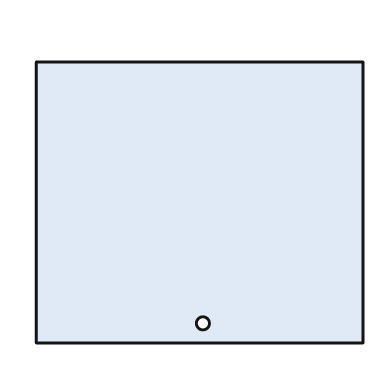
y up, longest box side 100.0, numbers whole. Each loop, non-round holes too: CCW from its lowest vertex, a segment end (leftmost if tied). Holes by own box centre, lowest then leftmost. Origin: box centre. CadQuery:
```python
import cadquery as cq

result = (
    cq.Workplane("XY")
    .moveTo(-50.0, -43.0)
    .lineTo(50.0, -43.0)
    .lineTo(50.0, 43.0)
    .lineTo(-50.0, 43.0)
    .close()
    .moveTo(1.0, -37.0)
    .circle(2.0)
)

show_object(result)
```